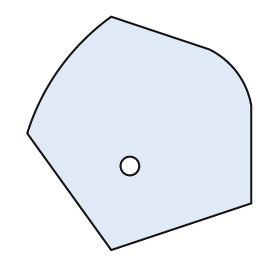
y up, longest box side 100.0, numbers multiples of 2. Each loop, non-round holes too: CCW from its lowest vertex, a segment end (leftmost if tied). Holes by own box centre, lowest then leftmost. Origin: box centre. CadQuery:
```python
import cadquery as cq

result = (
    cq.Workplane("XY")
    .moveTo(-12.0, -50.0)
    .lineTo(48.0, -30.0)
    .lineTo(48.0, 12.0)
    .threePointArc((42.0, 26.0), (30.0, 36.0))
    .lineTo(-12.0, 50.0)
    .threePointArc((-34.0, 28.0), (-48.0, 0.0))
    .close()
    .moveTo(-4.0, -14.0)
    .circle(4.0)
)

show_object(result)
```